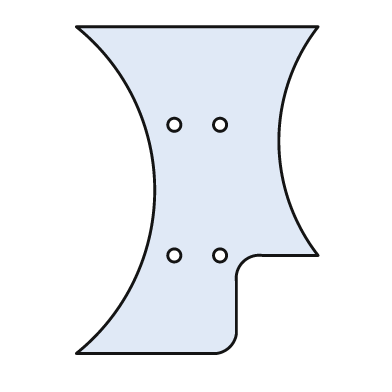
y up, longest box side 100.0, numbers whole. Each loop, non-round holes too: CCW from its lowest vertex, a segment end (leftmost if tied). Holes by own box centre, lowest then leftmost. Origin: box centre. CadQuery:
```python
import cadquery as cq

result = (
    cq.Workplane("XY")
    .moveTo(-37.0, -50.0)
    .lineTo(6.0, -50.0)
    .threePointArc((10.0, -48.0), (12.0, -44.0))
    .lineTo(12.0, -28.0)
    .threePointArc((14.0, -22.0), (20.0, -20.0))
    .lineTo(37.0, -20.0)
    .threePointArc((25.0, 15.0), (37.0, 50.0))
    .lineTo(-37.0, 50.0)
    .threePointArc((-13.0, 0.0), (-37.0, -50.0))
    .close()
    .moveTo(-7.0, -20.0)
    .circle(2.0)
    .moveTo(7.0, -20.0)
    .circle(2.0)
    .moveTo(-7.0, 20.0)
    .circle(2.0)
    .moveTo(7.0, 20.0)
    .circle(2.0)
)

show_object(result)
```